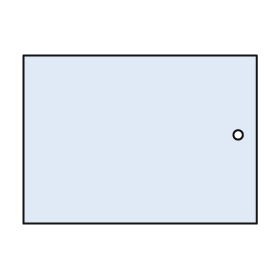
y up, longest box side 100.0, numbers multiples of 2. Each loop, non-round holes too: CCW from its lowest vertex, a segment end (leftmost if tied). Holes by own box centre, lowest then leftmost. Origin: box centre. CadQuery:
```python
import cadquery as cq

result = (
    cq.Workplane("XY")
    .moveTo(-50.0, -36.0)
    .lineTo(50.0, -36.0)
    .lineTo(50.0, 36.0)
    .lineTo(-50.0, 36.0)
    .close()
    .moveTo(42.0, 2.0)
    .circle(2.0)
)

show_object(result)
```